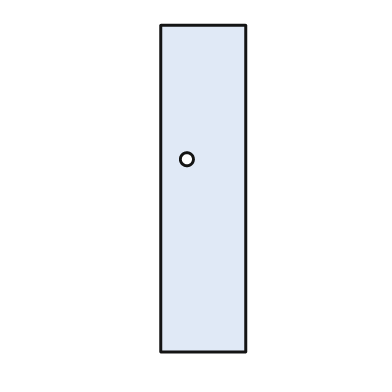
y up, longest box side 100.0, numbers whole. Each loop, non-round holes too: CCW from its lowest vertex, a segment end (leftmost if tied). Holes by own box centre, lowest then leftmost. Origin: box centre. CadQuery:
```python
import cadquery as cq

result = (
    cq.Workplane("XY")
    .moveTo(-13.0, -50.0)
    .lineTo(13.0, -50.0)
    .lineTo(13.0, 50.0)
    .lineTo(-13.0, 50.0)
    .close()
    .moveTo(-5.0, 9.0)
    .circle(2.0)
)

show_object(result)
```